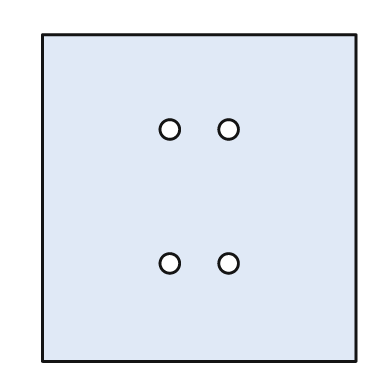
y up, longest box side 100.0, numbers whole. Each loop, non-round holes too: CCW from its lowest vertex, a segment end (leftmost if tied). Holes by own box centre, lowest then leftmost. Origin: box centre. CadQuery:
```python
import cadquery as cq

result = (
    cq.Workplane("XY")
    .moveTo(-48.0, -50.0)
    .lineTo(48.0, -50.0)
    .lineTo(48.0, 50.0)
    .lineTo(-48.0, 50.0)
    .close()
    .moveTo(-9.0, -20.0)
    .circle(3.0)
    .moveTo(9.0, -20.0)
    .circle(3.0)
    .moveTo(-9.0, 21.0)
    .circle(3.0)
    .moveTo(9.0, 21.0)
    .circle(3.0)
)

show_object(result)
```